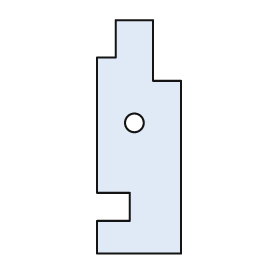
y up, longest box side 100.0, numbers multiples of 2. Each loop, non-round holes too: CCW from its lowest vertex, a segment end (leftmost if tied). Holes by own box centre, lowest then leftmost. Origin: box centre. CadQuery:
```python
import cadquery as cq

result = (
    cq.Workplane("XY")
    .moveTo(-18.0, -50.0)
    .lineTo(18.0, -50.0)
    .lineTo(18.0, 24.0)
    .lineTo(6.0, 24.0)
    .lineTo(6.0, 50.0)
    .lineTo(-10.0, 50.0)
    .lineTo(-10.0, 34.0)
    .lineTo(-18.0, 34.0)
    .lineTo(-18.0, -24.0)
    .lineTo(-4.0, -24.0)
    .lineTo(-4.0, -36.0)
    .lineTo(-18.0, -36.0)
    .close()
    .moveTo(-2.0, 6.0)
    .circle(4.0)
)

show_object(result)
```